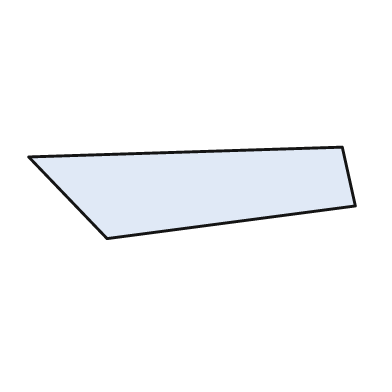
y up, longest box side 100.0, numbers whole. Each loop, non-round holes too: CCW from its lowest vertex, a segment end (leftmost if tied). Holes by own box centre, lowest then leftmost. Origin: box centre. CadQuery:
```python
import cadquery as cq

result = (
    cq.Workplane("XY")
    .moveTo(-26.0, -14.0)
    .lineTo(50.0, -4.0)
    .lineTo(46.0, 14.0)
    .lineTo(-50.0, 11.0)
    .close()
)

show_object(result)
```